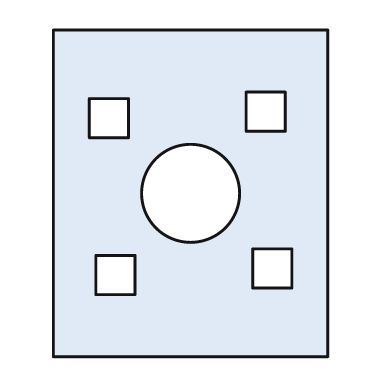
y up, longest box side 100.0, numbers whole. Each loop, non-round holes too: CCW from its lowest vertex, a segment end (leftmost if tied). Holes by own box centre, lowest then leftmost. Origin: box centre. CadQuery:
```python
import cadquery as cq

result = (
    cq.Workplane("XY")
    .moveTo(-42.0, -50.0)
    .lineTo(42.0, -50.0)
    .lineTo(42.0, 50.0)
    .lineTo(-42.0, 50.0)
    .close()
    .moveTo(-29.0, -31.0)
    .lineTo(-17.0, -31.0)
    .lineTo(-17.0, -19.0)
    .lineTo(-29.0, -19.0)
    .close()
    .moveTo(19.0, -29.0)
    .lineTo(31.0, -29.0)
    .lineTo(31.0, -17.0)
    .lineTo(19.0, -17.0)
    .close()
    .moveTo(0.0, 0.0)
    .circle(15.0)
    .moveTo(-31.0, 17.0)
    .lineTo(-19.0, 17.0)
    .lineTo(-19.0, 29.0)
    .lineTo(-31.0, 29.0)
    .close()
    .moveTo(17.0, 19.0)
    .lineTo(29.0, 19.0)
    .lineTo(29.0, 31.0)
    .lineTo(17.0, 31.0)
    .close()
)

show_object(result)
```